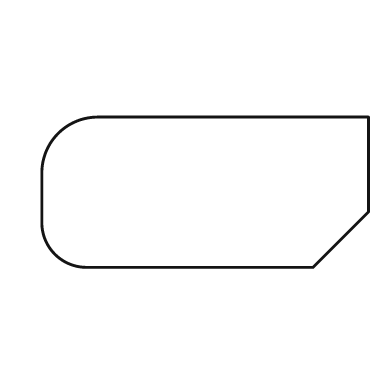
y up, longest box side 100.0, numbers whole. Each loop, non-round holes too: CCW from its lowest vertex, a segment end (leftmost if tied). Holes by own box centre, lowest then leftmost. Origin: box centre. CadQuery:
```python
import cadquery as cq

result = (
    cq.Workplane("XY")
    .moveTo(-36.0, -23.0)
    .lineTo(33.0, -23.0)
    .lineTo(50.0, -6.0)
    .lineTo(50.0, 23.0)
    .lineTo(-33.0, 23.0)
    .threePointArc((-45.0, 18.0), (-50.0, 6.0))
    .lineTo(-50.0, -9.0)
    .threePointArc((-46.0, -19.0), (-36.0, -23.0))
    .close()
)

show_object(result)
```